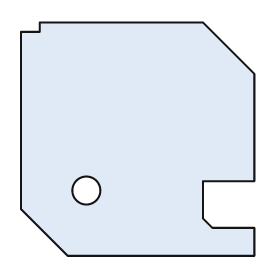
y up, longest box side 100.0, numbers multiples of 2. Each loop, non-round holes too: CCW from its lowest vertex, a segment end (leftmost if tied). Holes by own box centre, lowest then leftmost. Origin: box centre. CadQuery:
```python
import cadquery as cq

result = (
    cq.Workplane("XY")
    .moveTo(-30.0, -50.0)
    .lineTo(50.0, -50.0)
    .lineTo(50.0, -38.0)
    .lineTo(32.0, -38.0)
    .lineTo(28.0, -34.0)
    .lineTo(28.0, -18.0)
    .lineTo(50.0, -18.0)
    .lineTo(50.0, 28.0)
    .lineTo(28.0, 50.0)
    .lineTo(-42.0, 50.0)
    .lineTo(-42.0, 46.0)
    .lineTo(-50.0, 46.0)
    .lineTo(-50.0, -30.0)
    .close()
    .moveTo(-22.0, -22.0)
    .circle(6.0)
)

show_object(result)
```